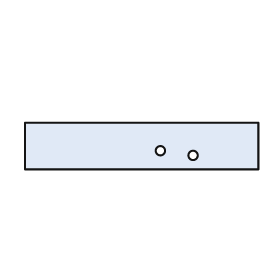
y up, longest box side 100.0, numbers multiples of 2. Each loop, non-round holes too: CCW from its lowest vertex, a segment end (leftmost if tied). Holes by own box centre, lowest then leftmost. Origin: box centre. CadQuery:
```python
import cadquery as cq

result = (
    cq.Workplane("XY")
    .moveTo(-50.0, -10.0)
    .lineTo(50.0, -10.0)
    .lineTo(50.0, 10.0)
    .lineTo(-50.0, 10.0)
    .close()
    .moveTo(22.0, -4.0)
    .circle(2.0)
    .moveTo(8.0, -2.0)
    .circle(2.0)
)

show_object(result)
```